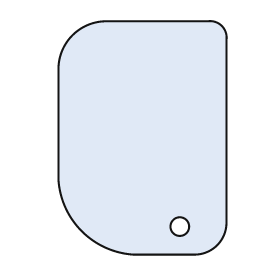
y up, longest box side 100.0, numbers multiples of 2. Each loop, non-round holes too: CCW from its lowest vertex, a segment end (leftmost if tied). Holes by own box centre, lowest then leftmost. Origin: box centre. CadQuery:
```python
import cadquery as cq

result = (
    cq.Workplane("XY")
    .moveTo(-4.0, -50.0)
    .lineTo(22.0, -50.0)
    .threePointArc((32.0, -46.0), (36.0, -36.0))
    .lineTo(36.0, 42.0)
    .threePointArc((34.0, 48.0), (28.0, 50.0))
    .lineTo(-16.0, 50.0)
    .threePointArc((-30.0, 44.0), (-36.0, 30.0))
    .lineTo(-36.0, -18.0)
    .threePointArc((-26.0, -40.0), (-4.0, -50.0))
    .close()
    .moveTo(16.0, -38.0)
    .circle(4.0)
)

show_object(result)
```